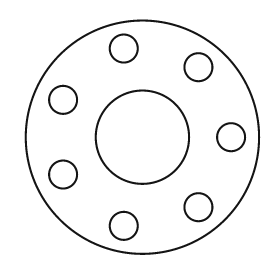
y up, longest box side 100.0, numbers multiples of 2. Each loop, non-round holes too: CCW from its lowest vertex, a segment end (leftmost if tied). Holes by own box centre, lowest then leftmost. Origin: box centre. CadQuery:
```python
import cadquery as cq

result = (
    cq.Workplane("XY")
    .moveTo(0.0, 0.0)
    .circle(50.0)
    .moveTo(-8.0, -38.0)
    .circle(6.0)
    .moveTo(24.0, -30.0)
    .circle(6.0)
    .moveTo(-34.0, -16.0)
    .circle(6.0)
    .moveTo(0.0, 0.0)
    .circle(20.0)
    .moveTo(38.0, 0.0)
    .circle(6.0)
    .moveTo(-34.0, 16.0)
    .circle(6.0)
    .moveTo(24.0, 30.0)
    .circle(6.0)
    .moveTo(-8.0, 38.0)
    .circle(6.0)
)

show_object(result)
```